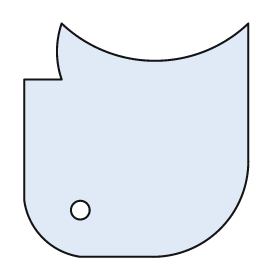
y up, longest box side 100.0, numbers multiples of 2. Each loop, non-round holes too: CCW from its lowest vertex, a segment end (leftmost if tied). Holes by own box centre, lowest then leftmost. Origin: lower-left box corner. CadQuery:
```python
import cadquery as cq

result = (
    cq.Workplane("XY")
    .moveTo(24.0, 0.0)
    .lineTo(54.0, 0.0)
    .threePointArc((84.0, 12.0), (96.0, 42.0))
    .lineTo(96.0, 100.0)
    .threePointArc((56.0, 84.0), (16.0, 100.0))
    .threePointArc((14.0, 88.0), (16.0, 76.0))
    .lineTo(0.0, 76.0)
    .lineTo(0.0, 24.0)
    .threePointArc((8.0, 8.0), (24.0, 0.0))
    .close()
    .moveTo(24.0, 20.0)
    .circle(4.0)
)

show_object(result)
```